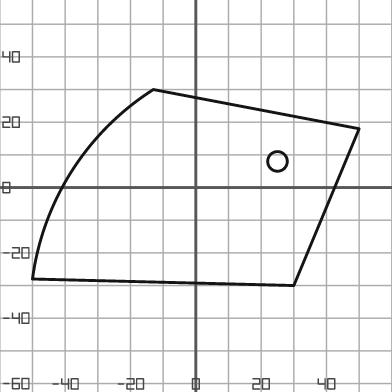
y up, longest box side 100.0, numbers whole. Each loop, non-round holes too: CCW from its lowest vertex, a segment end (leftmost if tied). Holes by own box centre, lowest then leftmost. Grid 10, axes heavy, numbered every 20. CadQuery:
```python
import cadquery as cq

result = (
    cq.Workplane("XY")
    .moveTo(30.0, -30.0)
    .lineTo(50.0, 18.0)
    .lineTo(-13.0, 30.0)
    .threePointArc((-38.0, 5.0), (-50.0, -28.0))
    .close()
    .moveTo(25.0, 8.0)
    .circle(3.0)
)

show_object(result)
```